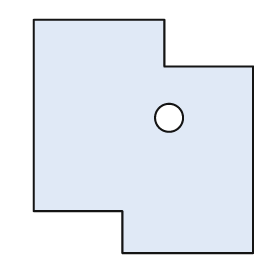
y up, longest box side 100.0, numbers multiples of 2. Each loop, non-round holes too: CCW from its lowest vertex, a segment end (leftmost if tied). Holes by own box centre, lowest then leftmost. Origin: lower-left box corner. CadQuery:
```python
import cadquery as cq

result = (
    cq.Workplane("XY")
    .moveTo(38.0, 0.0)
    .lineTo(94.0, 0.0)
    .lineTo(94.0, 80.0)
    .lineTo(56.0, 80.0)
    .lineTo(56.0, 100.0)
    .lineTo(0.0, 100.0)
    .lineTo(0.0, 18.0)
    .lineTo(38.0, 18.0)
    .close()
    .moveTo(58.0, 58.0)
    .circle(6.0)
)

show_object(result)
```